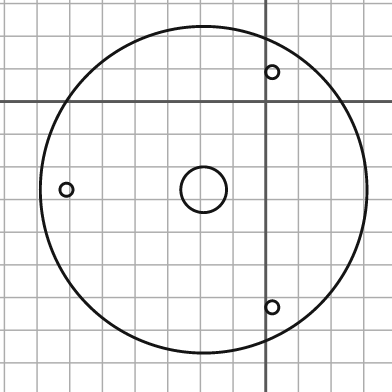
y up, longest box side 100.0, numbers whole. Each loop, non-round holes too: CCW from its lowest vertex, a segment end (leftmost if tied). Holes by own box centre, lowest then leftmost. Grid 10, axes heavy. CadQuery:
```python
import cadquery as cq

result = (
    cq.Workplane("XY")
    .moveTo(-19.0, -27.0)
    .circle(50.0)
    .moveTo(2.0, -63.0)
    .circle(2.0)
    .moveTo(-61.0, -27.0)
    .circle(2.0)
    .moveTo(-19.0, -27.0)
    .circle(7.0)
    .moveTo(2.0, 9.0)
    .circle(2.0)
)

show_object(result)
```